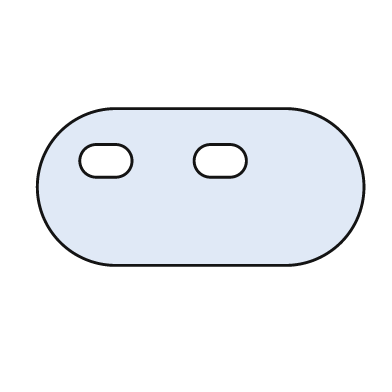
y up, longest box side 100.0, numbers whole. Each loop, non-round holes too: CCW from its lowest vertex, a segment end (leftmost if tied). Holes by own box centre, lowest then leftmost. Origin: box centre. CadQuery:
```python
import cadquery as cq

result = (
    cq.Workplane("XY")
    .moveTo(-26.0, -24.0)
    .lineTo(26.0, -24.0)
    .threePointArc((50.0, 0.0), (26.0, 24.0))
    .lineTo(-26.0, 24.0)
    .threePointArc((-50.0, 0.0), (-26.0, -24.0))
    .close()
    .moveTo(-32.0, 3.0)
    .lineTo(-26.0, 3.0)
    .threePointArc((-21.0, 8.0), (-26.0, 13.0))
    .lineTo(-32.0, 13.0)
    .threePointArc((-37.0, 8.0), (-32.0, 3.0))
    .close()
    .moveTo(3.0, 3.0)
    .lineTo(9.0, 3.0)
    .threePointArc((14.0, 8.0), (9.0, 13.0))
    .lineTo(3.0, 13.0)
    .threePointArc((-2.0, 8.0), (3.0, 3.0))
    .close()
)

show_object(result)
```